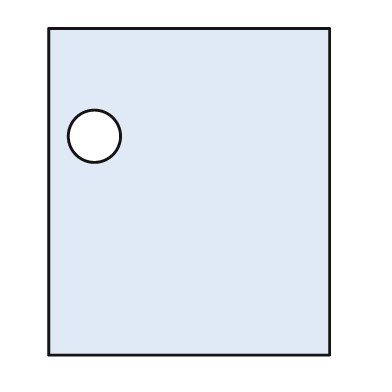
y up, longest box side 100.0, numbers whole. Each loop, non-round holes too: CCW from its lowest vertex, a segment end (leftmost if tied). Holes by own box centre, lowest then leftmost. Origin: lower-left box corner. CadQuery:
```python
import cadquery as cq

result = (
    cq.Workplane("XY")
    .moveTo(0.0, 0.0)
    .lineTo(86.0, 0.0)
    .lineTo(86.0, 100.0)
    .lineTo(0.0, 100.0)
    .close()
    .moveTo(14.0, 67.0)
    .circle(8.0)
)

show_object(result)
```